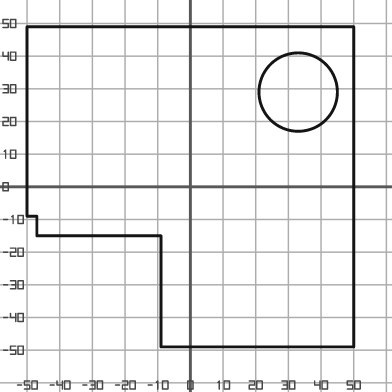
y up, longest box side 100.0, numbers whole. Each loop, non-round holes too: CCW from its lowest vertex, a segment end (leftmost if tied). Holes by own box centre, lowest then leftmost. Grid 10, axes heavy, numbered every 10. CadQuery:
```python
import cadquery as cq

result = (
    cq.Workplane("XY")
    .moveTo(-9.0, -49.0)
    .lineTo(50.0, -49.0)
    .lineTo(50.0, 49.0)
    .lineTo(-50.0, 49.0)
    .lineTo(-50.0, -9.0)
    .lineTo(-47.0, -9.0)
    .lineTo(-47.0, -15.0)
    .lineTo(-9.0, -15.0)
    .close()
    .moveTo(33.0, 29.0)
    .circle(12.0)
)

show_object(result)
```